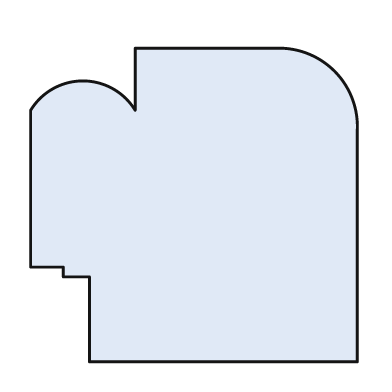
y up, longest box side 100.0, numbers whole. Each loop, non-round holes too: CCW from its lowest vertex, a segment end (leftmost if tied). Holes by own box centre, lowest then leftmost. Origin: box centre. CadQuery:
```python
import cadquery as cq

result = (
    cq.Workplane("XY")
    .moveTo(-32.0, -48.0)
    .lineTo(50.0, -48.0)
    .lineTo(50.0, 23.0)
    .threePointArc((43.0, 41.0), (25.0, 48.0))
    .lineTo(-18.0, 48.0)
    .lineTo(-18.0, 29.0)
    .threePointArc((-34.0, 38.0), (-50.0, 29.0))
    .lineTo(-50.0, -19.0)
    .lineTo(-40.0, -19.0)
    .lineTo(-40.0, -22.0)
    .lineTo(-32.0, -22.0)
    .close()
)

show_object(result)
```